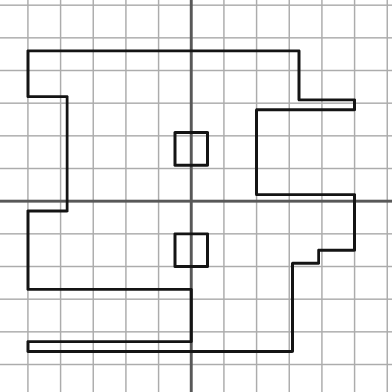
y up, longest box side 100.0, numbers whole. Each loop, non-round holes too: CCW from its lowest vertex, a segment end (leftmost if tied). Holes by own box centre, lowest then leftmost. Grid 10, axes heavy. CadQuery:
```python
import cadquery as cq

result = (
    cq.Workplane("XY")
    .moveTo(-50.0, -46.0)
    .lineTo(31.0, -46.0)
    .lineTo(31.0, -19.0)
    .lineTo(39.0, -19.0)
    .lineTo(39.0, -15.0)
    .lineTo(50.0, -15.0)
    .lineTo(50.0, 2.0)
    .lineTo(20.0, 2.0)
    .lineTo(20.0, 28.0)
    .lineTo(50.0, 28.0)
    .lineTo(50.0, 31.0)
    .lineTo(33.0, 31.0)
    .lineTo(33.0, 46.0)
    .lineTo(-50.0, 46.0)
    .lineTo(-50.0, 32.0)
    .lineTo(-38.0, 32.0)
    .lineTo(-38.0, -3.0)
    .lineTo(-50.0, -3.0)
    .lineTo(-50.0, -27.0)
    .lineTo(0.0, -27.0)
    .lineTo(0.0, -43.0)
    .lineTo(-50.0, -43.0)
    .close()
    .moveTo(-5.0, -20.0)
    .lineTo(5.0, -20.0)
    .lineTo(5.0, -10.0)
    .lineTo(-5.0, -10.0)
    .close()
    .moveTo(-5.0, 11.0)
    .lineTo(5.0, 11.0)
    .lineTo(5.0, 21.0)
    .lineTo(-5.0, 21.0)
    .close()
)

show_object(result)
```